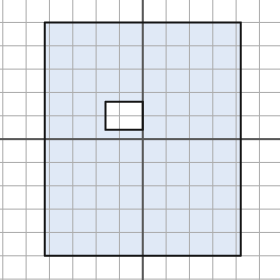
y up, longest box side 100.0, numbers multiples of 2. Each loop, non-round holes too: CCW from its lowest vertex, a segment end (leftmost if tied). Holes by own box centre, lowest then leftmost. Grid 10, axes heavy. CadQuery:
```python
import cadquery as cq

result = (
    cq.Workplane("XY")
    .moveTo(-42.0, -50.0)
    .lineTo(42.0, -50.0)
    .lineTo(42.0, 50.0)
    .lineTo(-42.0, 50.0)
    .close()
    .moveTo(-16.0, 4.0)
    .lineTo(0.0, 4.0)
    .lineTo(0.0, 16.0)
    .lineTo(-16.0, 16.0)
    .close()
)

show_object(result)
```